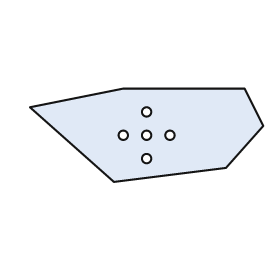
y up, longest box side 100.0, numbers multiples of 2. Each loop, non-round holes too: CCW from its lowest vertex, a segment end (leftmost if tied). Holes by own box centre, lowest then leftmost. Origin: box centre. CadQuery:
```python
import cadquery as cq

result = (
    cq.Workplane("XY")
    .moveTo(-14.0, -20.0)
    .lineTo(34.0, -14.0)
    .lineTo(50.0, 4.0)
    .lineTo(42.0, 20.0)
    .lineTo(-10.0, 20.0)
    .lineTo(-50.0, 12.0)
    .close()
    .moveTo(0.0, -10.0)
    .circle(2.0)
    .moveTo(-10.0, 0.0)
    .circle(2.0)
    .moveTo(0.0, 0.0)
    .circle(2.0)
    .moveTo(10.0, 0.0)
    .circle(2.0)
    .moveTo(0.0, 10.0)
    .circle(2.0)
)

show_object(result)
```